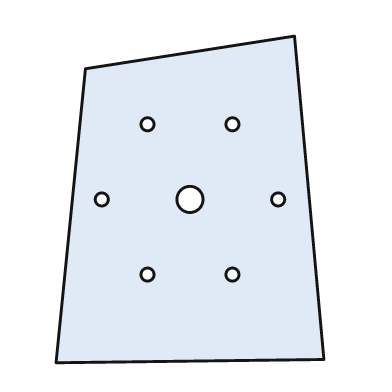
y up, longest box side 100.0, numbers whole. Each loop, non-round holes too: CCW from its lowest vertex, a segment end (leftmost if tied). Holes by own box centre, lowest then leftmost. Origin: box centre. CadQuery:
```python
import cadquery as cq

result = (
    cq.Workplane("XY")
    .moveTo(-41.0, -50.0)
    .lineTo(41.0, -49.0)
    .lineTo(32.0, 50.0)
    .lineTo(-32.0, 40.0)
    .close()
    .moveTo(-13.0, -23.0)
    .circle(2.0)
    .moveTo(13.0, -23.0)
    .circle(2.0)
    .moveTo(-27.0, 0.0)
    .circle(2.0)
    .moveTo(0.0, 0.0)
    .circle(4.0)
    .moveTo(27.0, 0.0)
    .circle(2.0)
    .moveTo(-13.0, 23.0)
    .circle(2.0)
    .moveTo(13.0, 23.0)
    .circle(2.0)
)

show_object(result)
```